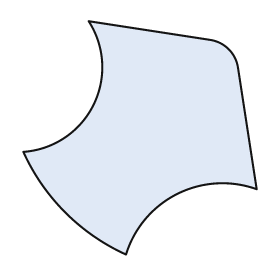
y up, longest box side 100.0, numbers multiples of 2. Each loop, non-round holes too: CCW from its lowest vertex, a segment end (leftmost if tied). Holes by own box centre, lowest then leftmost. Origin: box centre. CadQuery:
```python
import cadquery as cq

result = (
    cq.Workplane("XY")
    .moveTo(-6.0, -50.0)
    .threePointArc((16.0, -24.0), (50.0, -22.0))
    .lineTo(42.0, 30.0)
    .threePointArc((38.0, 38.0), (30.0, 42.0))
    .lineTo(-22.0, 50.0)
    .threePointArc((-20.0, 14.0), (-50.0, -6.0))
    .threePointArc((-32.0, -32.0), (-6.0, -50.0))
    .close()
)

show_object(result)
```